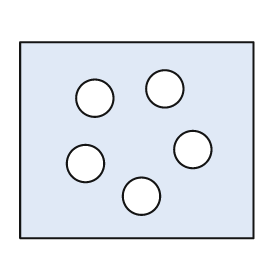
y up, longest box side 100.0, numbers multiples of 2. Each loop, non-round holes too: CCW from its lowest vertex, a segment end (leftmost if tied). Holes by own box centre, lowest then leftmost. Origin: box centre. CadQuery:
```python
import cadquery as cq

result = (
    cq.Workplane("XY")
    .moveTo(-50.0, -42.0)
    .lineTo(50.0, -42.0)
    .lineTo(50.0, 42.0)
    .lineTo(-50.0, 42.0)
    .close()
    .moveTo(2.0, -24.0)
    .circle(8.0)
    .moveTo(-22.0, -10.0)
    .circle(8.0)
    .moveTo(24.0, -4.0)
    .circle(8.0)
    .moveTo(-18.0, 18.0)
    .circle(8.0)
    .moveTo(12.0, 22.0)
    .circle(8.0)
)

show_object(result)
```